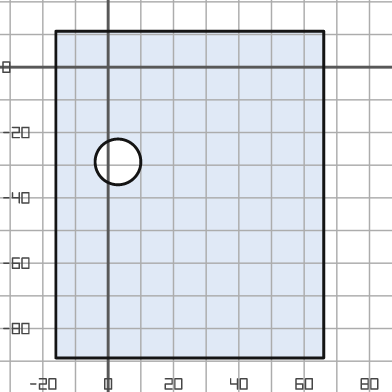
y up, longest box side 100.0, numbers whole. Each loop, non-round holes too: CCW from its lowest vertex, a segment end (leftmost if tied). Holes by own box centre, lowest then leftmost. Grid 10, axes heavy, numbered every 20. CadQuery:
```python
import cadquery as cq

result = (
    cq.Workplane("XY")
    .moveTo(-16.0, -89.0)
    .lineTo(66.0, -89.0)
    .lineTo(66.0, 11.0)
    .lineTo(-16.0, 11.0)
    .close()
    .moveTo(3.0, -29.0)
    .circle(7.0)
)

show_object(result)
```